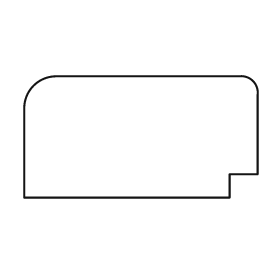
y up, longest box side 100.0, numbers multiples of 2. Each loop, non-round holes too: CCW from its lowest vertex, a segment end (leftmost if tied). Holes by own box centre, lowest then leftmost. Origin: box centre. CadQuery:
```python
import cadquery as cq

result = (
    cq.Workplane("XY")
    .moveTo(-50.0, -26.0)
    .lineTo(38.0, -26.0)
    .lineTo(38.0, -16.0)
    .lineTo(50.0, -16.0)
    .lineTo(50.0, 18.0)
    .threePointArc((48.0, 24.0), (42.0, 26.0))
    .lineTo(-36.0, 26.0)
    .threePointArc((-46.0, 22.0), (-50.0, 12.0))
    .close()
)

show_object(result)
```